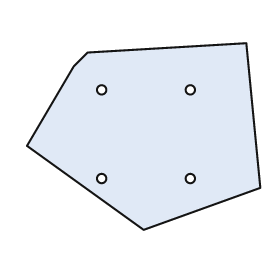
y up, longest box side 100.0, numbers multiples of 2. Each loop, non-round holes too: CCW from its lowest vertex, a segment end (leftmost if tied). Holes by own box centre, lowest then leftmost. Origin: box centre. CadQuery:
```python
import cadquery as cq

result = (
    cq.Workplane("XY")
    .moveTo(0.0, -40.0)
    .lineTo(50.0, -22.0)
    .lineTo(44.0, 40.0)
    .lineTo(-24.0, 36.0)
    .lineTo(-30.0, 30.0)
    .lineTo(-50.0, -4.0)
    .close()
    .moveTo(-18.0, -18.0)
    .circle(2.0)
    .moveTo(20.0, -18.0)
    .circle(2.0)
    .moveTo(-18.0, 20.0)
    .circle(2.0)
    .moveTo(20.0, 20.0)
    .circle(2.0)
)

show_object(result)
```